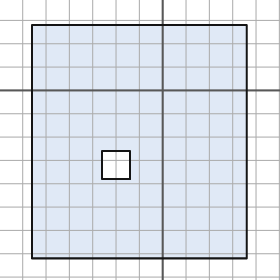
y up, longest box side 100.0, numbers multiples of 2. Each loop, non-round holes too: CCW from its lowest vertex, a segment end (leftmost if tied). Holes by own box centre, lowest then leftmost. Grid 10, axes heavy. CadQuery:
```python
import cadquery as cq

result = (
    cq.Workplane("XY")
    .moveTo(-56.0, -72.0)
    .lineTo(36.0, -72.0)
    .lineTo(36.0, 28.0)
    .lineTo(-56.0, 28.0)
    .close()
    .moveTo(-26.0, -38.0)
    .lineTo(-14.0, -38.0)
    .lineTo(-14.0, -26.0)
    .lineTo(-26.0, -26.0)
    .close()
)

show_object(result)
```